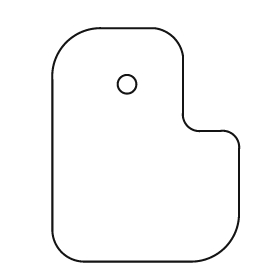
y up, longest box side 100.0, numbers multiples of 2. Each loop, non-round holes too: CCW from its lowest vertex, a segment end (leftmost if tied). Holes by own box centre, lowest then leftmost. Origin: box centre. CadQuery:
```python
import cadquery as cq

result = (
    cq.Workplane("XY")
    .moveTo(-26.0, -50.0)
    .lineTo(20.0, -50.0)
    .threePointArc((34.0, -44.0), (40.0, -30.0))
    .lineTo(40.0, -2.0)
    .threePointArc((38.0, 4.0), (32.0, 6.0))
    .lineTo(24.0, 6.0)
    .threePointArc((18.0, 8.0), (16.0, 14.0))
    .lineTo(16.0, 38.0)
    .threePointArc((12.0, 46.0), (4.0, 50.0))
    .lineTo(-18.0, 50.0)
    .threePointArc((-34.0, 44.0), (-40.0, 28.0))
    .lineTo(-40.0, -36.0)
    .threePointArc((-36.0, -46.0), (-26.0, -50.0))
    .close()
    .moveTo(-8.0, 26.0)
    .circle(4.0)
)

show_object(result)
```